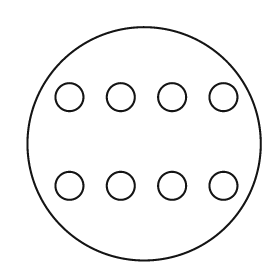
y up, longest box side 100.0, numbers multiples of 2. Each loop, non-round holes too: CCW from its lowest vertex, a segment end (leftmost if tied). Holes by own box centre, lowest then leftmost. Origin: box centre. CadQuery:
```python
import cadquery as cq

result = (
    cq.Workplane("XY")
    .moveTo(0.0, 0.0)
    .circle(50.0)
    .moveTo(-32.0, -18.0)
    .circle(6.0)
    .moveTo(-10.0, -18.0)
    .circle(6.0)
    .moveTo(12.0, -18.0)
    .circle(6.0)
    .moveTo(34.0, -18.0)
    .circle(6.0)
    .moveTo(-32.0, 20.0)
    .circle(6.0)
    .moveTo(-10.0, 20.0)
    .circle(6.0)
    .moveTo(12.0, 20.0)
    .circle(6.0)
    .moveTo(34.0, 20.0)
    .circle(6.0)
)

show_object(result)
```